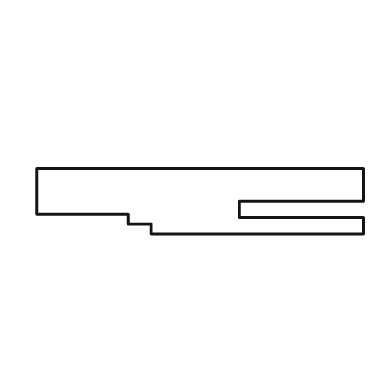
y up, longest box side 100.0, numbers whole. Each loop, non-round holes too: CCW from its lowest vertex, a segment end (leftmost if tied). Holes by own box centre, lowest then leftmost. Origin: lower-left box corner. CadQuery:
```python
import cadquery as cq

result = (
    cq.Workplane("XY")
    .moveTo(35.0, 0.0)
    .lineTo(100.0, 0.0)
    .lineTo(100.0, 5.0)
    .lineTo(62.0, 5.0)
    .lineTo(62.0, 10.0)
    .lineTo(100.0, 10.0)
    .lineTo(100.0, 20.0)
    .lineTo(0.0, 20.0)
    .lineTo(0.0, 6.0)
    .lineTo(28.0, 6.0)
    .lineTo(28.0, 3.0)
    .lineTo(35.0, 3.0)
    .close()
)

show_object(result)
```